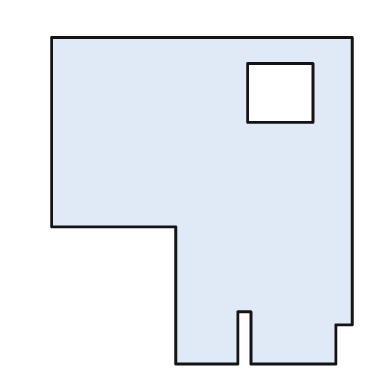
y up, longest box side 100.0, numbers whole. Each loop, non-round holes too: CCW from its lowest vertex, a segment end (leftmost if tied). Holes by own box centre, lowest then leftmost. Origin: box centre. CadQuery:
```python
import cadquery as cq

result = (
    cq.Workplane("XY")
    .moveTo(-8.0, -50.0)
    .lineTo(11.0, -50.0)
    .lineTo(11.0, -34.0)
    .lineTo(15.0, -34.0)
    .lineTo(15.0, -50.0)
    .lineTo(41.0, -50.0)
    .lineTo(41.0, -38.0)
    .lineTo(46.0, -38.0)
    .lineTo(46.0, 50.0)
    .lineTo(-46.0, 50.0)
    .lineTo(-46.0, -8.0)
    .lineTo(-8.0, -8.0)
    .close()
    .moveTo(14.0, 24.0)
    .lineTo(34.0, 24.0)
    .lineTo(34.0, 42.0)
    .lineTo(14.0, 42.0)
    .close()
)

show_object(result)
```